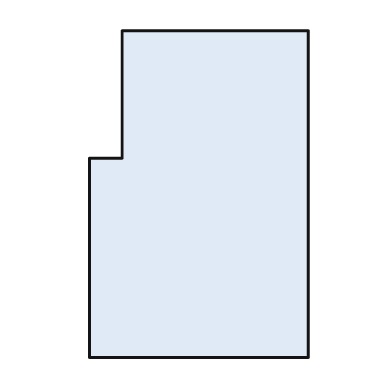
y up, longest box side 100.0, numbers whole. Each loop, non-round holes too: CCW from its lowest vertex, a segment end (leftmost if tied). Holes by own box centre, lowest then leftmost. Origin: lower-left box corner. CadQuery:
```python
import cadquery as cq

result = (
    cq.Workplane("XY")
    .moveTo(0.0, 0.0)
    .lineTo(67.0, 0.0)
    .lineTo(67.0, 100.0)
    .lineTo(10.0, 100.0)
    .lineTo(10.0, 61.0)
    .lineTo(0.0, 61.0)
    .close()
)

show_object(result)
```